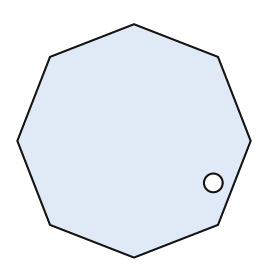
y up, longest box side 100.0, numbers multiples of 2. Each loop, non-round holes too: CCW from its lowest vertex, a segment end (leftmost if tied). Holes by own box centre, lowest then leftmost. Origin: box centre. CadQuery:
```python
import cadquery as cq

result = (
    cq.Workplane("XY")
    .moveTo(0.0, -50.0)
    .lineTo(36.0, -36.0)
    .lineTo(50.0, 0.0)
    .lineTo(36.0, 36.0)
    .lineTo(0.0, 50.0)
    .lineTo(-36.0, 36.0)
    .lineTo(-50.0, 0.0)
    .lineTo(-36.0, -36.0)
    .close()
    .moveTo(34.0, -18.0)
    .circle(4.0)
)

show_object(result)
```